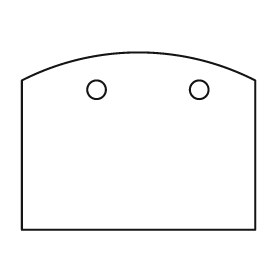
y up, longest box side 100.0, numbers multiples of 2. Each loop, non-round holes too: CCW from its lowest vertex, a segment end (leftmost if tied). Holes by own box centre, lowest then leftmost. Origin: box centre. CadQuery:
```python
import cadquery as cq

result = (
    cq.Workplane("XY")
    .moveTo(-50.0, -38.0)
    .lineTo(50.0, -38.0)
    .lineTo(50.0, 26.0)
    .threePointArc((0.0, 38.0), (-50.0, 26.0))
    .close()
    .moveTo(-18.0, 22.0)
    .circle(4.0)
    .moveTo(26.0, 22.0)
    .circle(4.0)
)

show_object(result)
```